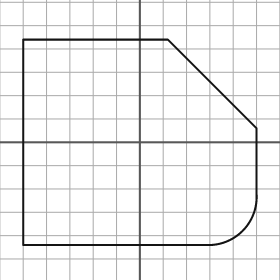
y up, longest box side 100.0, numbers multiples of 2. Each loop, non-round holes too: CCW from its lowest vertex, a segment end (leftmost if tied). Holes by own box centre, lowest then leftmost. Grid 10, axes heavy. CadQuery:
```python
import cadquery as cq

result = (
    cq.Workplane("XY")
    .moveTo(-50.0, -44.0)
    .lineTo(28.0, -44.0)
    .threePointArc((44.0, -38.0), (50.0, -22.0))
    .lineTo(50.0, 6.0)
    .lineTo(12.0, 44.0)
    .lineTo(-50.0, 44.0)
    .close()
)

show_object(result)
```